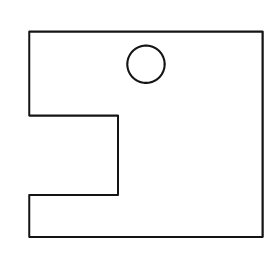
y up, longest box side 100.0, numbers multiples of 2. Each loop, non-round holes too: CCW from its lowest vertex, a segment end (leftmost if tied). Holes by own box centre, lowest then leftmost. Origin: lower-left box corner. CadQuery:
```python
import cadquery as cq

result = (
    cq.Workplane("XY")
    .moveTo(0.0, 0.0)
    .lineTo(100.0, 0.0)
    .lineTo(100.0, 88.0)
    .lineTo(0.0, 88.0)
    .lineTo(0.0, 52.0)
    .lineTo(38.0, 52.0)
    .lineTo(38.0, 18.0)
    .lineTo(0.0, 18.0)
    .close()
    .moveTo(50.0, 74.0)
    .circle(8.0)
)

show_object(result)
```